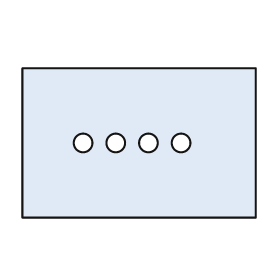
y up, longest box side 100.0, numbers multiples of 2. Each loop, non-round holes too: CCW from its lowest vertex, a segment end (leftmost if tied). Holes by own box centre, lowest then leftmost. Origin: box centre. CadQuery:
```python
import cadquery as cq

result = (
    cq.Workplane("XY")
    .moveTo(-50.0, -32.0)
    .lineTo(50.0, -32.0)
    .lineTo(50.0, 32.0)
    .lineTo(-50.0, 32.0)
    .close()
    .moveTo(-24.0, 0.0)
    .circle(4.0)
    .moveTo(-10.0, 0.0)
    .circle(4.0)
    .moveTo(4.0, 0.0)
    .circle(4.0)
    .moveTo(18.0, 0.0)
    .circle(4.0)
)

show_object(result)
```